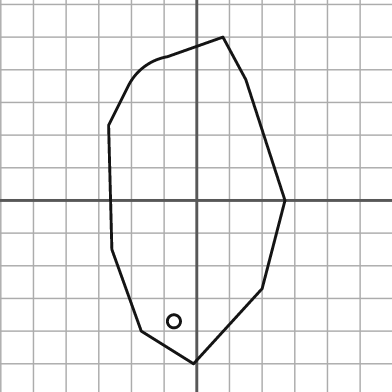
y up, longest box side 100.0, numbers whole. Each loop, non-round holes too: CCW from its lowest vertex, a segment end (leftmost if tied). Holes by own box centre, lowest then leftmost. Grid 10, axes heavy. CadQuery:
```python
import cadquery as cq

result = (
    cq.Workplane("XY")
    .moveTo(-1.0, -50.0)
    .lineTo(20.0, -27.0)
    .lineTo(27.0, 0.0)
    .lineTo(15.0, 37.0)
    .lineTo(8.0, 50.0)
    .lineTo(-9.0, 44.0)
    .threePointArc((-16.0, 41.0), (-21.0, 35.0))
    .lineTo(-27.0, 23.0)
    .lineTo(-26.0, -15.0)
    .lineTo(-17.0, -40.0)
    .close()
    .moveTo(-7.0, -37.0)
    .circle(2.0)
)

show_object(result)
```